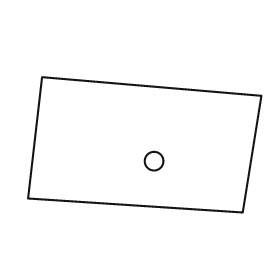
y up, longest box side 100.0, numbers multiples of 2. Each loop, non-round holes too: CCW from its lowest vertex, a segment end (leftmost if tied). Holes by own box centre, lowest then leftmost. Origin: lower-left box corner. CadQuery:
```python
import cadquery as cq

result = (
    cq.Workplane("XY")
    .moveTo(92.0, 0.0)
    .lineTo(100.0, 50.0)
    .lineTo(6.0, 58.0)
    .lineTo(0.0, 6.0)
    .close()
    .moveTo(54.0, 22.0)
    .circle(4.0)
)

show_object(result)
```